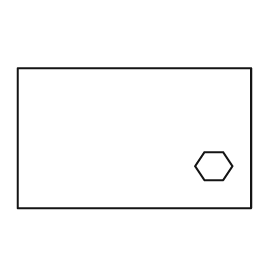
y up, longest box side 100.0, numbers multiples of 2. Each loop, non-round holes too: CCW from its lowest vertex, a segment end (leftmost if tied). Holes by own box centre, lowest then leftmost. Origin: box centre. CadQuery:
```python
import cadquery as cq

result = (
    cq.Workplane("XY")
    .moveTo(-50.0, -30.0)
    .lineTo(50.0, -30.0)
    .lineTo(50.0, 30.0)
    .lineTo(-50.0, 30.0)
    .close()
    .moveTo(30.0, -18.0)
    .lineTo(38.0, -18.0)
    .lineTo(42.0, -12.0)
    .lineTo(38.0, -6.0)
    .lineTo(30.0, -6.0)
    .lineTo(26.0, -12.0)
    .close()
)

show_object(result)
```